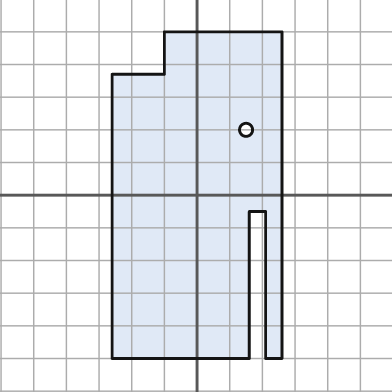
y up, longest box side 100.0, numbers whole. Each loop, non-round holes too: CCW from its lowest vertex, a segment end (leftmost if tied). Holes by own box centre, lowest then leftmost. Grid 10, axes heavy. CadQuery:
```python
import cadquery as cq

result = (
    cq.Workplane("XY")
    .moveTo(-26.0, -50.0)
    .lineTo(16.0, -50.0)
    .lineTo(16.0, -5.0)
    .lineTo(21.0, -5.0)
    .lineTo(21.0, -50.0)
    .lineTo(26.0, -50.0)
    .lineTo(26.0, 50.0)
    .lineTo(-10.0, 50.0)
    .lineTo(-10.0, 37.0)
    .lineTo(-26.0, 37.0)
    .close()
    .moveTo(15.0, 20.0)
    .circle(2.0)
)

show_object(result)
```